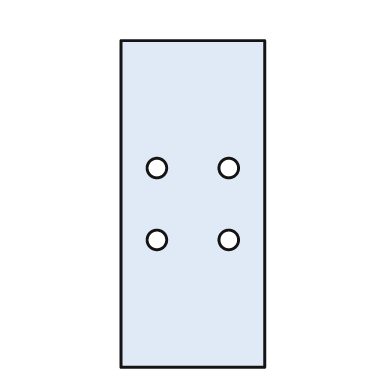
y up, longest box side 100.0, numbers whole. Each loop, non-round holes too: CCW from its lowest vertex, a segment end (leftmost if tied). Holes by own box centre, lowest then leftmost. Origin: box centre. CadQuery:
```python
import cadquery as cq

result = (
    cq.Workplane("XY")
    .moveTo(-22.0, -50.0)
    .lineTo(22.0, -50.0)
    .lineTo(22.0, 50.0)
    .lineTo(-22.0, 50.0)
    .close()
    .moveTo(-11.0, -11.0)
    .circle(3.0)
    .moveTo(11.0, -11.0)
    .circle(3.0)
    .moveTo(-11.0, 11.0)
    .circle(3.0)
    .moveTo(11.0, 11.0)
    .circle(3.0)
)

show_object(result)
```